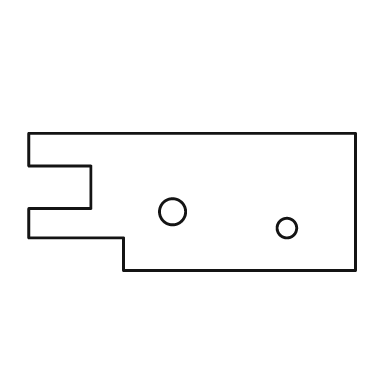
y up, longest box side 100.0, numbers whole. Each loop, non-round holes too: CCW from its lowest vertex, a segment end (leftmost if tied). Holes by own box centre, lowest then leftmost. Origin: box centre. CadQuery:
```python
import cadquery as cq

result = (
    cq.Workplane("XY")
    .moveTo(-21.0, -21.0)
    .lineTo(50.0, -21.0)
    .lineTo(50.0, 21.0)
    .lineTo(-50.0, 21.0)
    .lineTo(-50.0, 11.0)
    .lineTo(-31.0, 11.0)
    .lineTo(-31.0, -2.0)
    .lineTo(-50.0, -2.0)
    .lineTo(-50.0, -11.0)
    .lineTo(-21.0, -11.0)
    .close()
    .moveTo(29.0, -8.0)
    .circle(3.0)
    .moveTo(-6.0, -3.0)
    .circle(4.0)
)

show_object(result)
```